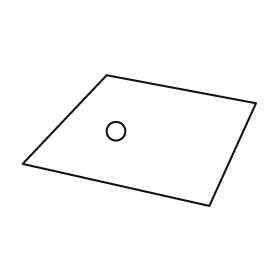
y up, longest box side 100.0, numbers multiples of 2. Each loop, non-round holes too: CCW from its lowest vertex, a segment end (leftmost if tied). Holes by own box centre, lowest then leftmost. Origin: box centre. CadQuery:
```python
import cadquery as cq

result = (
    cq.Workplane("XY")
    .moveTo(30.0, -28.0)
    .lineTo(50.0, 16.0)
    .lineTo(-14.0, 28.0)
    .lineTo(-50.0, -10.0)
    .close()
    .moveTo(-10.0, 4.0)
    .circle(4.0)
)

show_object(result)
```